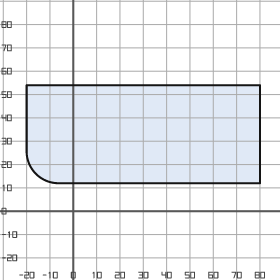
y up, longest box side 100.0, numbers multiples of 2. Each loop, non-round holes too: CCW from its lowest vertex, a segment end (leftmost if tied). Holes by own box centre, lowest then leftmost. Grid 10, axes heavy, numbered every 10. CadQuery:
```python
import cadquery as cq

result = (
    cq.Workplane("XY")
    .moveTo(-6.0, 12.0)
    .lineTo(80.0, 12.0)
    .lineTo(80.0, 54.0)
    .lineTo(-20.0, 54.0)
    .lineTo(-20.0, 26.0)
    .threePointArc((-16.0, 16.0), (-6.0, 12.0))
    .close()
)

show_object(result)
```